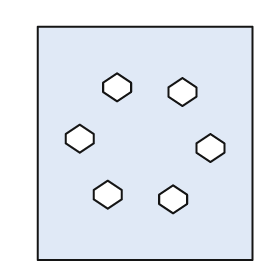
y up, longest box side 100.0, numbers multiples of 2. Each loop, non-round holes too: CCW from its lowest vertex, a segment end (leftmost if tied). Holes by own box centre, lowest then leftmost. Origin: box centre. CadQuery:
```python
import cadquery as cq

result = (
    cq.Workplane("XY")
    .moveTo(-46.0, -50.0)
    .lineTo(46.0, -50.0)
    .lineTo(46.0, 50.0)
    .lineTo(-46.0, 50.0)
    .close()
    .moveTo(12.0, -30.0)
    .lineTo(18.0, -26.0)
    .lineTo(18.0, -22.0)
    .lineTo(12.0, -18.0)
    .lineTo(6.0, -22.0)
    .lineTo(6.0, -26.0)
    .close()
    .moveTo(-16.0, -28.0)
    .lineTo(-10.0, -24.0)
    .lineTo(-10.0, -20.0)
    .lineTo(-16.0, -16.0)
    .lineTo(-22.0, -20.0)
    .lineTo(-22.0, -24.0)
    .close()
    .moveTo(28.0, -8.0)
    .lineTo(34.0, -4.0)
    .lineTo(34.0, 0.0)
    .lineTo(28.0, 4.0)
    .lineTo(22.0, 0.0)
    .lineTo(22.0, -4.0)
    .close()
    .moveTo(-28.0, -4.0)
    .lineTo(-22.0, 0.0)
    .lineTo(-22.0, 4.0)
    .lineTo(-28.0, 8.0)
    .lineTo(-34.0, 4.0)
    .lineTo(-34.0, 0.0)
    .close()
    .moveTo(16.0, 16.0)
    .lineTo(22.0, 20.0)
    .lineTo(22.0, 24.0)
    .lineTo(16.0, 28.0)
    .lineTo(10.0, 24.0)
    .lineTo(10.0, 20.0)
    .close()
    .moveTo(-12.0, 18.0)
    .lineTo(-6.0, 22.0)
    .lineTo(-6.0, 26.0)
    .lineTo(-12.0, 30.0)
    .lineTo(-18.0, 26.0)
    .lineTo(-18.0, 22.0)
    .close()
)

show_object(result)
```